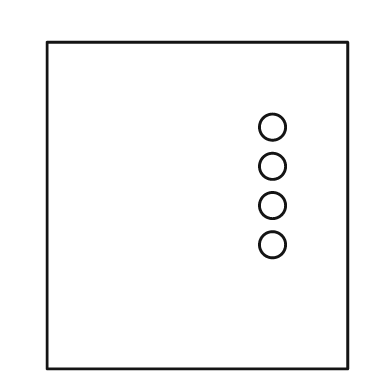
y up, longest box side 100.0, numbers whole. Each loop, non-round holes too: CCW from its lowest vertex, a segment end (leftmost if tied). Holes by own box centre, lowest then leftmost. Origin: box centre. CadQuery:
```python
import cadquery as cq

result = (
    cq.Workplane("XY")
    .moveTo(-46.0, -50.0)
    .lineTo(46.0, -50.0)
    .lineTo(46.0, 50.0)
    .lineTo(-46.0, 50.0)
    .close()
    .moveTo(23.0, -12.0)
    .circle(4.0)
    .moveTo(23.0, 0.0)
    .circle(4.0)
    .moveTo(23.0, 12.0)
    .circle(4.0)
    .moveTo(23.0, 24.0)
    .circle(4.0)
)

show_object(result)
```